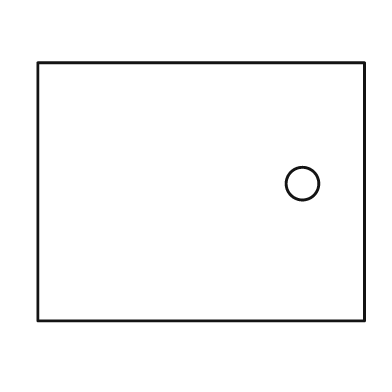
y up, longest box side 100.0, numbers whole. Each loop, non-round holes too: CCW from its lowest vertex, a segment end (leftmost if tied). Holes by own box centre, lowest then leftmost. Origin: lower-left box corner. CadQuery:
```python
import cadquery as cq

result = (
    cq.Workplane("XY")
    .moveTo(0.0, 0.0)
    .lineTo(100.0, 0.0)
    .lineTo(100.0, 79.0)
    .lineTo(0.0, 79.0)
    .close()
    .moveTo(81.0, 42.0)
    .circle(5.0)
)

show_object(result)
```